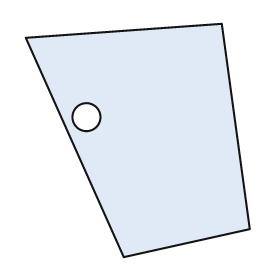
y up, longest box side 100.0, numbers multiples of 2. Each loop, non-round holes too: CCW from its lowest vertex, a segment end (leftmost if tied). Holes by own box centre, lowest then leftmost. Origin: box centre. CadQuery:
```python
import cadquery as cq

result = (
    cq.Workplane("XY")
    .moveTo(-6.0, -50.0)
    .lineTo(48.0, -38.0)
    .lineTo(36.0, 50.0)
    .lineTo(-48.0, 44.0)
    .close()
    .moveTo(-22.0, 10.0)
    .circle(6.0)
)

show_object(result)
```